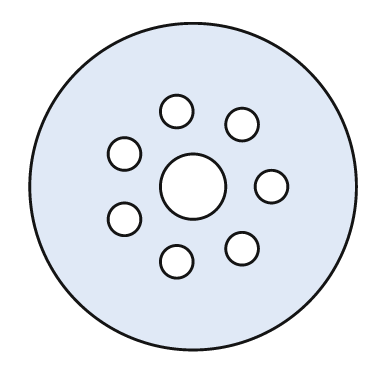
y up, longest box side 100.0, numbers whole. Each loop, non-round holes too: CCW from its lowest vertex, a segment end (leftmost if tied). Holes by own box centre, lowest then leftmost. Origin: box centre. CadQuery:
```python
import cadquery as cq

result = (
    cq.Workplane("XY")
    .moveTo(0.0, 0.0)
    .circle(50.0)
    .moveTo(-5.0, -23.0)
    .circle(5.0)
    .moveTo(15.0, -19.0)
    .circle(5.0)
    .moveTo(-21.0, -10.0)
    .circle(5.0)
    .moveTo(0.0, 0.0)
    .circle(10.0)
    .moveTo(24.0, 0.0)
    .circle(5.0)
    .moveTo(-21.0, 10.0)
    .circle(5.0)
    .moveTo(15.0, 19.0)
    .circle(5.0)
    .moveTo(-5.0, 23.0)
    .circle(5.0)
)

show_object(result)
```